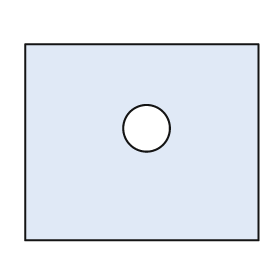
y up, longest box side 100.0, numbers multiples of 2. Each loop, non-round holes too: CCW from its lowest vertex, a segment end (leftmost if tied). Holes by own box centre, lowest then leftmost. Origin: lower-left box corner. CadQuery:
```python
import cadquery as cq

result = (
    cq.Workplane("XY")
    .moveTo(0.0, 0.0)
    .lineTo(100.0, 0.0)
    .lineTo(100.0, 84.0)
    .lineTo(0.0, 84.0)
    .close()
    .moveTo(52.0, 48.0)
    .circle(10.0)
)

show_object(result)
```